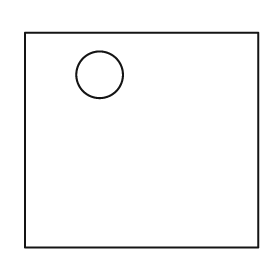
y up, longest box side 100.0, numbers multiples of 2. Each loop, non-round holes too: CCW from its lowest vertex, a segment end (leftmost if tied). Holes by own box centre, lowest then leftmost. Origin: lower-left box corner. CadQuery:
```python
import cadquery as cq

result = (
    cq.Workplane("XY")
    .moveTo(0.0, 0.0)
    .lineTo(100.0, 0.0)
    .lineTo(100.0, 92.0)
    .lineTo(0.0, 92.0)
    .close()
    .moveTo(32.0, 74.0)
    .circle(10.0)
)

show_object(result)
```